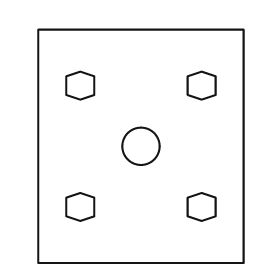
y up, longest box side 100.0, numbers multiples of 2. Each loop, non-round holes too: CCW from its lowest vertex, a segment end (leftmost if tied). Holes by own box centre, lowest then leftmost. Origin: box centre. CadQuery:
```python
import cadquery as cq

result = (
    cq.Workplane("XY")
    .moveTo(-44.0, -50.0)
    .lineTo(44.0, -50.0)
    .lineTo(44.0, 50.0)
    .lineTo(-44.0, 50.0)
    .close()
    .moveTo(-26.0, -32.0)
    .lineTo(-20.0, -30.0)
    .lineTo(-20.0, -22.0)
    .lineTo(-26.0, -20.0)
    .lineTo(-32.0, -22.0)
    .lineTo(-32.0, -30.0)
    .close()
    .moveTo(26.0, -32.0)
    .lineTo(32.0, -30.0)
    .lineTo(32.0, -22.0)
    .lineTo(26.0, -20.0)
    .lineTo(20.0, -22.0)
    .lineTo(20.0, -30.0)
    .close()
    .moveTo(0.0, 0.0)
    .circle(8.0)
    .moveTo(-26.0, 20.0)
    .lineTo(-20.0, 22.0)
    .lineTo(-20.0, 30.0)
    .lineTo(-26.0, 32.0)
    .lineTo(-32.0, 30.0)
    .lineTo(-32.0, 22.0)
    .close()
    .moveTo(26.0, 20.0)
    .lineTo(32.0, 22.0)
    .lineTo(32.0, 30.0)
    .lineTo(26.0, 32.0)
    .lineTo(20.0, 30.0)
    .lineTo(20.0, 22.0)
    .close()
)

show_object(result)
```